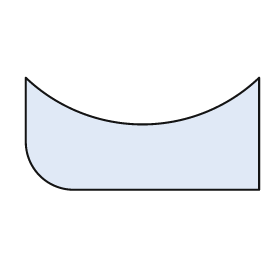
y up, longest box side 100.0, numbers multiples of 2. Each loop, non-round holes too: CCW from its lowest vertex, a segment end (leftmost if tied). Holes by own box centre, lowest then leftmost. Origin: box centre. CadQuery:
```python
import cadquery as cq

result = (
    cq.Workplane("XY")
    .moveTo(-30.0, -24.0)
    .lineTo(50.0, -24.0)
    .lineTo(50.0, 24.0)
    .threePointArc((0.0, 4.0), (-50.0, 24.0))
    .lineTo(-50.0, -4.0)
    .threePointArc((-44.0, -18.0), (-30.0, -24.0))
    .close()
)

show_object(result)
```